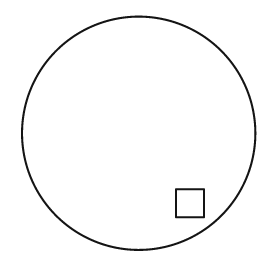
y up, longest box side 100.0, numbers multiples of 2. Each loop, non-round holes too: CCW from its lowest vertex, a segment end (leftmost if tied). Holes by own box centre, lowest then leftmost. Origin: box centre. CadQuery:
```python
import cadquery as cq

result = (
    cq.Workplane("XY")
    .moveTo(0.0, 0.0)
    .circle(50.0)
    .moveTo(16.0, -36.0)
    .lineTo(28.0, -36.0)
    .lineTo(28.0, -24.0)
    .lineTo(16.0, -24.0)
    .close()
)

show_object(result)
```